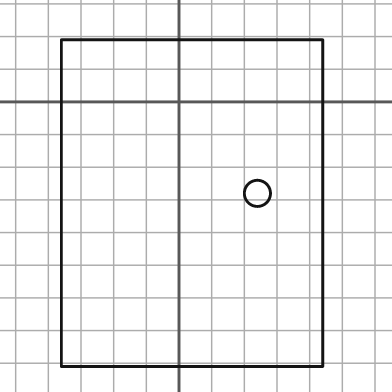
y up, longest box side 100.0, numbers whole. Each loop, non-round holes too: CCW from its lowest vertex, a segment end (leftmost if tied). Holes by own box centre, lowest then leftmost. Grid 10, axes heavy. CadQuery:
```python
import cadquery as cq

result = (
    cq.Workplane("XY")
    .moveTo(-36.0, -81.0)
    .lineTo(44.0, -81.0)
    .lineTo(44.0, 19.0)
    .lineTo(-36.0, 19.0)
    .close()
    .moveTo(24.0, -28.0)
    .circle(4.0)
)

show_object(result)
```